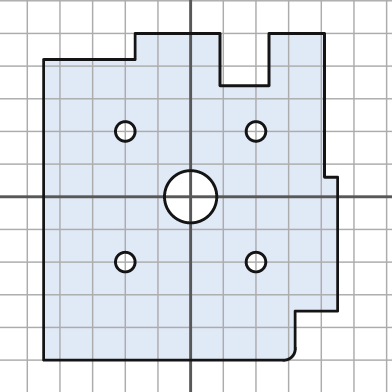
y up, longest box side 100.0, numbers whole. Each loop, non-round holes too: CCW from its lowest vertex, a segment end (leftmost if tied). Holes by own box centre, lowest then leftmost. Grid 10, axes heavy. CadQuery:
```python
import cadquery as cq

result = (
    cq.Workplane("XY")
    .moveTo(-45.0, -50.0)
    .lineTo(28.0, -50.0)
    .threePointArc((31.0, -49.0), (32.0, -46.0))
    .lineTo(32.0, -35.0)
    .lineTo(45.0, -35.0)
    .lineTo(45.0, 6.0)
    .lineTo(41.0, 6.0)
    .lineTo(41.0, 50.0)
    .lineTo(24.0, 50.0)
    .lineTo(24.0, 34.0)
    .lineTo(9.0, 34.0)
    .lineTo(9.0, 50.0)
    .lineTo(-17.0, 50.0)
    .lineTo(-17.0, 42.0)
    .lineTo(-45.0, 42.0)
    .close()
    .moveTo(-20.0, -20.0)
    .circle(3.0)
    .moveTo(20.0, -20.0)
    .circle(3.0)
    .moveTo(0.0, 0.0)
    .circle(8.0)
    .moveTo(-20.0, 20.0)
    .circle(3.0)
    .moveTo(20.0, 20.0)
    .circle(3.0)
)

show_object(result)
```